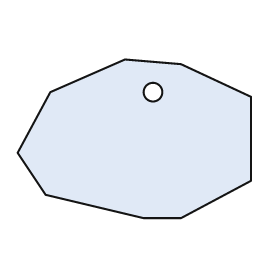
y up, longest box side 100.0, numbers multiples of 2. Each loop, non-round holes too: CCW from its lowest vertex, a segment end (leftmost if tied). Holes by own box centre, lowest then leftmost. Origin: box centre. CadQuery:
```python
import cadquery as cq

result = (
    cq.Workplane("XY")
    .moveTo(4.0, -34.0)
    .lineTo(20.0, -34.0)
    .lineTo(50.0, -18.0)
    .lineTo(50.0, 18.0)
    .lineTo(20.0, 32.0)
    .lineTo(-4.0, 34.0)
    .lineTo(-36.0, 20.0)
    .lineTo(-50.0, -6.0)
    .lineTo(-38.0, -24.0)
    .close()
    .moveTo(8.0, 20.0)
    .circle(4.0)
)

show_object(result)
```